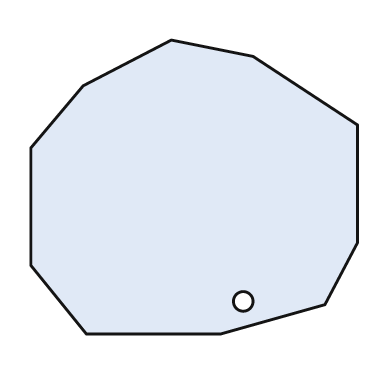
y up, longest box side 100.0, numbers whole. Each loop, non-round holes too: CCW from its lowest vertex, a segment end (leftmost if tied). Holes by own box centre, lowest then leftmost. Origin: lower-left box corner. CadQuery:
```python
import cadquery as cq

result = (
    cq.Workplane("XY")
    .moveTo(17.0, 0.0)
    .lineTo(58.0, 0.0)
    .lineTo(90.0, 9.0)
    .lineTo(100.0, 28.0)
    .lineTo(100.0, 64.0)
    .lineTo(68.0, 85.0)
    .lineTo(43.0, 90.0)
    .lineTo(16.0, 76.0)
    .lineTo(0.0, 57.0)
    .lineTo(0.0, 21.0)
    .close()
    .moveTo(65.0, 10.0)
    .circle(3.0)
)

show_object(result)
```